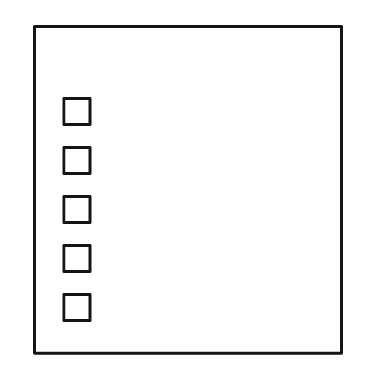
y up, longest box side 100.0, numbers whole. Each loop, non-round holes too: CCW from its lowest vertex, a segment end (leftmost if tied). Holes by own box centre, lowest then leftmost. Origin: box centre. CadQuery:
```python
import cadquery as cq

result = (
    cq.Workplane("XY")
    .moveTo(-47.0, -50.0)
    .lineTo(47.0, -50.0)
    .lineTo(47.0, 50.0)
    .lineTo(-47.0, 50.0)
    .close()
    .moveTo(-38.0, -40.0)
    .lineTo(-30.0, -40.0)
    .lineTo(-30.0, -32.0)
    .lineTo(-38.0, -32.0)
    .close()
    .moveTo(-38.0, -25.0)
    .lineTo(-30.0, -25.0)
    .lineTo(-30.0, -17.0)
    .lineTo(-38.0, -17.0)
    .close()
    .moveTo(-38.0, -10.0)
    .lineTo(-30.0, -10.0)
    .lineTo(-30.0, -2.0)
    .lineTo(-38.0, -2.0)
    .close()
    .moveTo(-38.0, 5.0)
    .lineTo(-30.0, 5.0)
    .lineTo(-30.0, 13.0)
    .lineTo(-38.0, 13.0)
    .close()
    .moveTo(-38.0, 20.0)
    .lineTo(-30.0, 20.0)
    .lineTo(-30.0, 28.0)
    .lineTo(-38.0, 28.0)
    .close()
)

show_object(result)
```